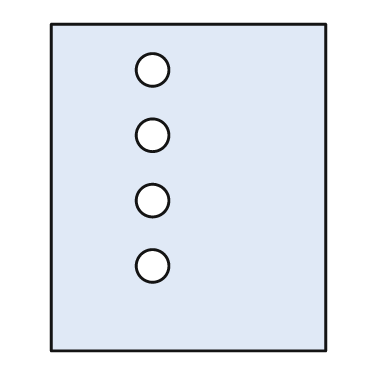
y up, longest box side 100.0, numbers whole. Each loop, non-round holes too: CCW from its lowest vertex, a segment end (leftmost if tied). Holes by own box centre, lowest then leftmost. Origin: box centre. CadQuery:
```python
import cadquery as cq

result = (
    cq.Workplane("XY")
    .moveTo(-42.0, -50.0)
    .lineTo(42.0, -50.0)
    .lineTo(42.0, 50.0)
    .lineTo(-42.0, 50.0)
    .close()
    .moveTo(-11.0, -24.0)
    .circle(5.0)
    .moveTo(-11.0, -4.0)
    .circle(5.0)
    .moveTo(-11.0, 16.0)
    .circle(5.0)
    .moveTo(-11.0, 36.0)
    .circle(5.0)
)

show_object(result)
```